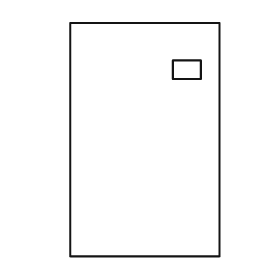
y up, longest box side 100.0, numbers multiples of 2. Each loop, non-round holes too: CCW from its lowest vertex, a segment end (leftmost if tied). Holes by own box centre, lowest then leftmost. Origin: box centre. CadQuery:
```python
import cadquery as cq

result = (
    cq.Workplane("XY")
    .moveTo(-32.0, -50.0)
    .lineTo(32.0, -50.0)
    .lineTo(32.0, 50.0)
    .lineTo(-32.0, 50.0)
    .close()
    .moveTo(12.0, 26.0)
    .lineTo(24.0, 26.0)
    .lineTo(24.0, 34.0)
    .lineTo(12.0, 34.0)
    .close()
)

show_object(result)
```